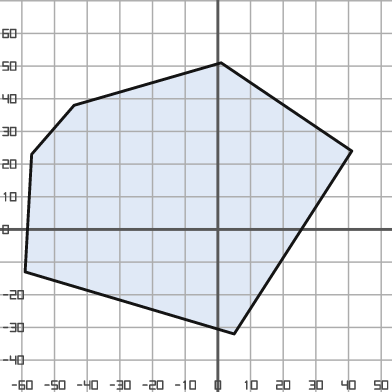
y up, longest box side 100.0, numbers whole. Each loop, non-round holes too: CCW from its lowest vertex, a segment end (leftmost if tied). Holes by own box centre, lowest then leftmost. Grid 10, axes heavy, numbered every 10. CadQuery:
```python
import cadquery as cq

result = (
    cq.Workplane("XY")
    .moveTo(5.0, -32.0)
    .lineTo(41.0, 24.0)
    .lineTo(1.0, 51.0)
    .lineTo(-44.0, 38.0)
    .lineTo(-57.0, 23.0)
    .lineTo(-59.0, -13.0)
    .close()
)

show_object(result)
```